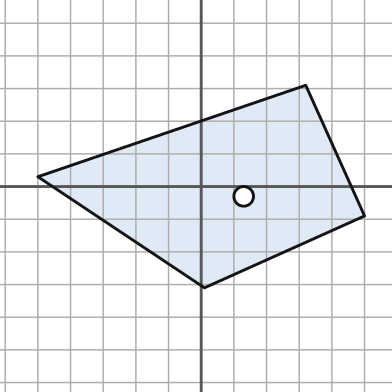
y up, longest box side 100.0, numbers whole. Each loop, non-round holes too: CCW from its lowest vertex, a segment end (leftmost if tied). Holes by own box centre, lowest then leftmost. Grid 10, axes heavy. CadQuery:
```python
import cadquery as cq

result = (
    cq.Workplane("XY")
    .moveTo(1.0, -31.0)
    .lineTo(50.0, -9.0)
    .lineTo(32.0, 31.0)
    .lineTo(-50.0, 3.0)
    .close()
    .moveTo(13.0, -3.0)
    .circle(3.0)
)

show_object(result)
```